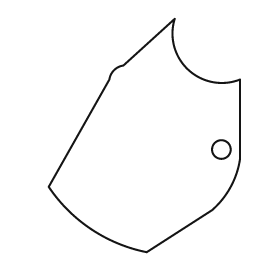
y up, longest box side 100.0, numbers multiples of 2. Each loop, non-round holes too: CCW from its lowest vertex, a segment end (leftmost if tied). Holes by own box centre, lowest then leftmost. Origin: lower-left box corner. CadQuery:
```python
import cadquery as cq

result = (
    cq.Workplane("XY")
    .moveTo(42.0, 0.0)
    .lineTo(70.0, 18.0)
    .threePointArc((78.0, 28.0), (82.0, 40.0))
    .lineTo(82.0, 74.0)
    .threePointArc((60.0, 78.0), (54.0, 100.0))
    .lineTo(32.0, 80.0)
    .threePointArc((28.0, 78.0), (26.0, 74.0))
    .lineTo(0.0, 28.0)
    .threePointArc((18.0, 10.0), (42.0, 0.0))
    .close()
    .moveTo(74.0, 44.0)
    .circle(4.0)
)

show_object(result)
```